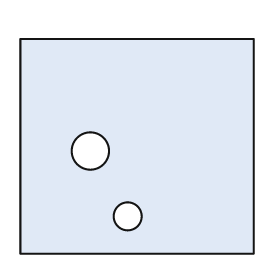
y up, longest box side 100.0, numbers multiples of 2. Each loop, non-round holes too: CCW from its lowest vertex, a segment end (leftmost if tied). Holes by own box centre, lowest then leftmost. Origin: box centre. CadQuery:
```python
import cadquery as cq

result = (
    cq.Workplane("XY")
    .moveTo(-50.0, -46.0)
    .lineTo(50.0, -46.0)
    .lineTo(50.0, 46.0)
    .lineTo(-50.0, 46.0)
    .close()
    .moveTo(-4.0, -30.0)
    .circle(6.0)
    .moveTo(-20.0, -2.0)
    .circle(8.0)
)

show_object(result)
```